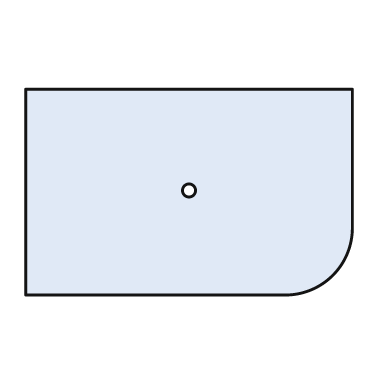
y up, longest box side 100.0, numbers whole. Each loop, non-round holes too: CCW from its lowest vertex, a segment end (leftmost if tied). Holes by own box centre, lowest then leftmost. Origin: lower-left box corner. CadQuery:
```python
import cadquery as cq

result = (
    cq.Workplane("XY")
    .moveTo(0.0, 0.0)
    .lineTo(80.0, 0.0)
    .threePointArc((94.0, 6.0), (100.0, 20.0))
    .lineTo(100.0, 63.0)
    .lineTo(0.0, 63.0)
    .close()
    .moveTo(50.0, 32.0)
    .circle(2.0)
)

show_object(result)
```